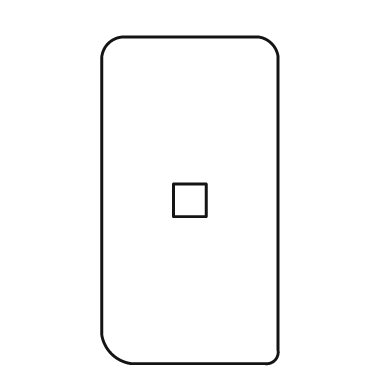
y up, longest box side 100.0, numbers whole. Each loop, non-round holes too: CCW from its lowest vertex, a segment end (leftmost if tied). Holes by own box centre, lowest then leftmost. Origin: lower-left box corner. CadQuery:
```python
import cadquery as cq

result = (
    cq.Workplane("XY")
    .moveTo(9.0, 0.0)
    .lineTo(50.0, 0.0)
    .threePointArc((53.0, 1.0), (54.0, 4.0))
    .lineTo(54.0, 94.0)
    .threePointArc((52.0, 98.0), (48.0, 100.0))
    .lineTo(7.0, 100.0)
    .threePointArc((2.0, 98.0), (0.0, 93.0))
    .lineTo(0.0, 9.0)
    .threePointArc((3.0, 3.0), (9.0, 0.0))
    .close()
    .moveTo(22.0, 45.0)
    .lineTo(32.0, 45.0)
    .lineTo(32.0, 55.0)
    .lineTo(22.0, 55.0)
    .close()
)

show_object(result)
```